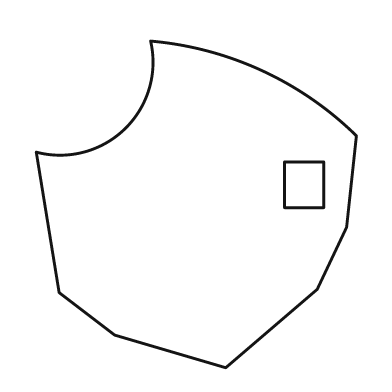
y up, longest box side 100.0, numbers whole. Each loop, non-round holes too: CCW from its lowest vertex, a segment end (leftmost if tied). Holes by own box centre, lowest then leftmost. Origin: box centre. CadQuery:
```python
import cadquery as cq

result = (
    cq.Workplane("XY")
    .moveTo(9.0, -50.0)
    .lineTo(37.0, -26.0)
    .lineTo(46.0, -7.0)
    .lineTo(49.0, 21.0)
    .threePointArc((20.0, 41.0), (-14.0, 50.0))
    .threePointArc((-22.0, 23.0), (-49.0, 16.0))
    .lineTo(-42.0, -27.0)
    .lineTo(-25.0, -40.0)
    .close()
    .moveTo(27.0, -1.0)
    .lineTo(39.0, -1.0)
    .lineTo(39.0, 13.0)
    .lineTo(27.0, 13.0)
    .close()
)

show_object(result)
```